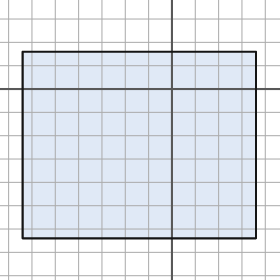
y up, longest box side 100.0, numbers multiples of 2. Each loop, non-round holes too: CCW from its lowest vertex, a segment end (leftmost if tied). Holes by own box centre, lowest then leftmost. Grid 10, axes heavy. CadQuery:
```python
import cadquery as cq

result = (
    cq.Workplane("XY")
    .moveTo(-64.0, -64.0)
    .lineTo(36.0, -64.0)
    .lineTo(36.0, 16.0)
    .lineTo(-64.0, 16.0)
    .close()
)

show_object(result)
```